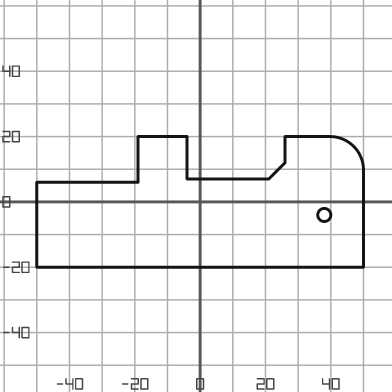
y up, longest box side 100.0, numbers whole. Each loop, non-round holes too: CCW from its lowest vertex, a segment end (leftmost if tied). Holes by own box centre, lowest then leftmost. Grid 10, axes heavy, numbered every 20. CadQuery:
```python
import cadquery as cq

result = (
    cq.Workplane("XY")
    .moveTo(-50.0, -20.0)
    .lineTo(50.0, -20.0)
    .lineTo(50.0, 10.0)
    .threePointArc((47.0, 17.0), (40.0, 20.0))
    .lineTo(26.0, 20.0)
    .lineTo(26.0, 12.0)
    .lineTo(21.0, 7.0)
    .lineTo(-4.0, 7.0)
    .lineTo(-4.0, 20.0)
    .lineTo(-19.0, 20.0)
    .lineTo(-19.0, 6.0)
    .lineTo(-50.0, 6.0)
    .close()
    .moveTo(38.0, -4.0)
    .circle(2.0)
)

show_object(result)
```